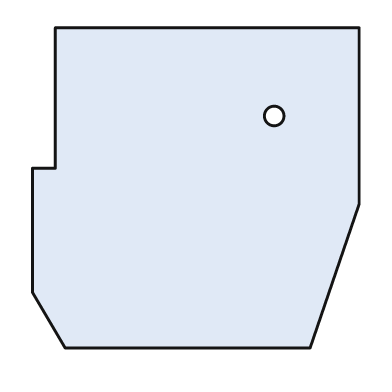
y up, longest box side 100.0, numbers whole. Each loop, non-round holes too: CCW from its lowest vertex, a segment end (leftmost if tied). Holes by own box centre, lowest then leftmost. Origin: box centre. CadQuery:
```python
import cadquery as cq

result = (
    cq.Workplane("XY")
    .moveTo(-40.0, -49.0)
    .lineTo(35.0, -49.0)
    .lineTo(50.0, -5.0)
    .lineTo(50.0, 49.0)
    .lineTo(-43.0, 49.0)
    .lineTo(-43.0, 6.0)
    .lineTo(-50.0, 6.0)
    .lineTo(-50.0, -32.0)
    .close()
    .moveTo(24.0, 22.0)
    .circle(3.0)
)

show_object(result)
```